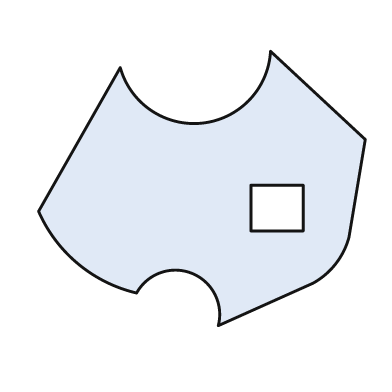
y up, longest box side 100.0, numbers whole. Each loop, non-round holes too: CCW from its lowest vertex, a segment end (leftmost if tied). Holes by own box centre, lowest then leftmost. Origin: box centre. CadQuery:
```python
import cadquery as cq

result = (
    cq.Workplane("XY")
    .moveTo(5.0, -42.0)
    .lineTo(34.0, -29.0)
    .threePointArc((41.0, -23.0), (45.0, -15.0))
    .lineTo(50.0, 15.0)
    .lineTo(21.0, 42.0)
    .threePointArc((0.0, 20.0), (-25.0, 37.0))
    .lineTo(-50.0, -7.0)
    .threePointArc((-38.0, -23.0), (-20.0, -32.0))
    .threePointArc((-3.0, -26.0), (5.0, -42.0))
    .close()
    .moveTo(15.0, -13.0)
    .lineTo(31.0, -13.0)
    .lineTo(31.0, 1.0)
    .lineTo(15.0, 1.0)
    .close()
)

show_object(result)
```